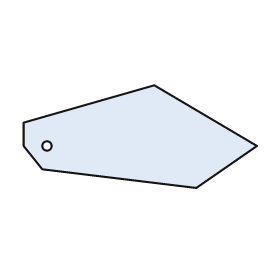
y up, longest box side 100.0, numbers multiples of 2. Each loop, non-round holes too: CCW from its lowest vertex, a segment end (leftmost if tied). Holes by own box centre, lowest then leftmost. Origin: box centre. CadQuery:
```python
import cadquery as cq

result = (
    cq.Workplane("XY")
    .moveTo(24.0, -22.0)
    .lineTo(50.0, -4.0)
    .lineTo(6.0, 22.0)
    .lineTo(-50.0, 6.0)
    .lineTo(-50.0, -4.0)
    .lineTo(-42.0, -14.0)
    .close()
    .moveTo(-40.0, -4.0)
    .circle(2.0)
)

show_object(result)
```